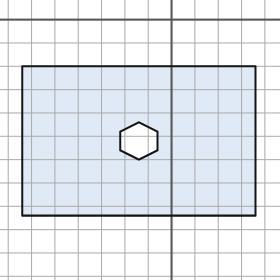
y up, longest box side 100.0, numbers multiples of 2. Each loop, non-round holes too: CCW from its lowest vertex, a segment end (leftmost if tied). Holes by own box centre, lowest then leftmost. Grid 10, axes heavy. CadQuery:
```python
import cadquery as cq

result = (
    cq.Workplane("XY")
    .moveTo(-64.0, -84.0)
    .lineTo(36.0, -84.0)
    .lineTo(36.0, -20.0)
    .lineTo(-64.0, -20.0)
    .close()
    .moveTo(-14.0, -60.0)
    .lineTo(-6.0, -56.0)
    .lineTo(-6.0, -48.0)
    .lineTo(-14.0, -44.0)
    .lineTo(-22.0, -48.0)
    .lineTo(-22.0, -56.0)
    .close()
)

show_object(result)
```